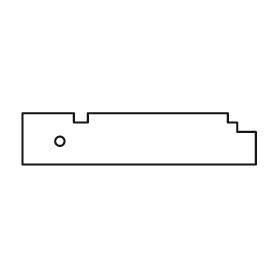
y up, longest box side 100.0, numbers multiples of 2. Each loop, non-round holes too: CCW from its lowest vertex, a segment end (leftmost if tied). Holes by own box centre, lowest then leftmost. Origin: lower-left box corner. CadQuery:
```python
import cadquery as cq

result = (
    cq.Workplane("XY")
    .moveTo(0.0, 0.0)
    .lineTo(100.0, 0.0)
    .lineTo(100.0, 14.0)
    .lineTo(92.0, 14.0)
    .lineTo(92.0, 18.0)
    .lineTo(88.0, 18.0)
    .lineTo(88.0, 22.0)
    .lineTo(28.0, 22.0)
    .lineTo(28.0, 18.0)
    .lineTo(22.0, 18.0)
    .lineTo(22.0, 22.0)
    .lineTo(0.0, 22.0)
    .close()
    .moveTo(16.0, 10.0)
    .circle(2.0)
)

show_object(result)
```